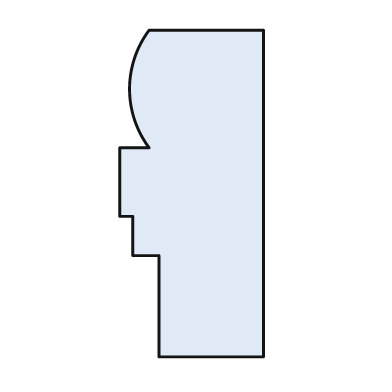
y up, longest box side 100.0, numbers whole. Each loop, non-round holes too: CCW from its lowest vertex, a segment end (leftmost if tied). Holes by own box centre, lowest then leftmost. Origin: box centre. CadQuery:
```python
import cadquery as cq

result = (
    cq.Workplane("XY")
    .moveTo(-10.0, -50.0)
    .lineTo(22.0, -50.0)
    .lineTo(22.0, 50.0)
    .lineTo(-13.0, 50.0)
    .threePointArc((-19.0, 32.0), (-13.0, 14.0))
    .lineTo(-22.0, 14.0)
    .lineTo(-22.0, -7.0)
    .lineTo(-18.0, -7.0)
    .lineTo(-18.0, -19.0)
    .lineTo(-10.0, -19.0)
    .close()
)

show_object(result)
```